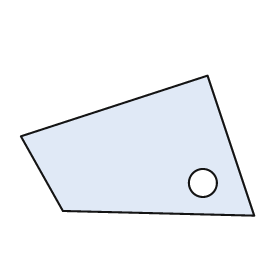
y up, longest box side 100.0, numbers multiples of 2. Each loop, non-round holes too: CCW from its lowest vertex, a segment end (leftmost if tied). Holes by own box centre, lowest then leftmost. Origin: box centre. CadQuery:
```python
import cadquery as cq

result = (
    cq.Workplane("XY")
    .moveTo(50.0, -30.0)
    .lineTo(30.0, 30.0)
    .lineTo(-50.0, 4.0)
    .lineTo(-32.0, -28.0)
    .close()
    .moveTo(28.0, -16.0)
    .circle(6.0)
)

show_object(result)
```